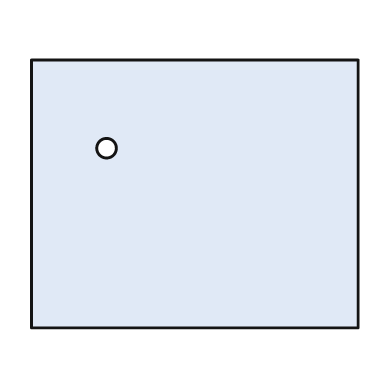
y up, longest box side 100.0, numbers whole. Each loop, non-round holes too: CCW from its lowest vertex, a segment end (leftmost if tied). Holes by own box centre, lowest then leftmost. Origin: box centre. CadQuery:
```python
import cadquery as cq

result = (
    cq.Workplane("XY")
    .moveTo(-50.0, -41.0)
    .lineTo(50.0, -41.0)
    .lineTo(50.0, 41.0)
    .lineTo(-50.0, 41.0)
    .close()
    .moveTo(-27.0, 14.0)
    .circle(3.0)
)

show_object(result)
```